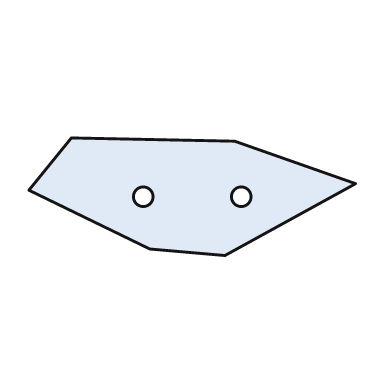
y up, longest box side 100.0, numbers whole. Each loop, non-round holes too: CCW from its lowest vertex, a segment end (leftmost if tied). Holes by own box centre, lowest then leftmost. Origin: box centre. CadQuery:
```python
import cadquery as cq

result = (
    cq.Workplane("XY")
    .moveTo(10.0, -18.0)
    .lineTo(50.0, 4.0)
    .lineTo(13.0, 17.0)
    .lineTo(-37.0, 18.0)
    .lineTo(-50.0, 2.0)
    .lineTo(-13.0, -16.0)
    .close()
    .moveTo(-15.0, 0.0)
    .circle(3.0)
    .moveTo(15.0, 0.0)
    .circle(3.0)
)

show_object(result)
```